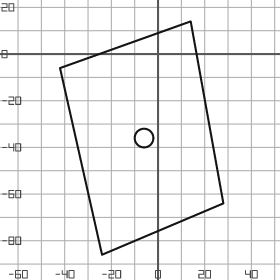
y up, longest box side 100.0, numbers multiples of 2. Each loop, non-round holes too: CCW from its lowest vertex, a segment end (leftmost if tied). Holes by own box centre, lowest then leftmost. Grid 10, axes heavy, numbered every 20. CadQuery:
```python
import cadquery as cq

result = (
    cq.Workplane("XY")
    .moveTo(-24.0, -86.0)
    .lineTo(28.0, -64.0)
    .lineTo(14.0, 14.0)
    .lineTo(-42.0, -6.0)
    .close()
    .moveTo(-6.0, -36.0)
    .circle(4.0)
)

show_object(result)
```